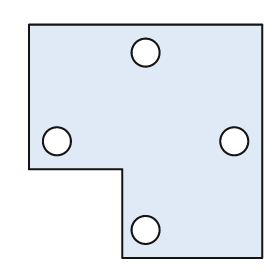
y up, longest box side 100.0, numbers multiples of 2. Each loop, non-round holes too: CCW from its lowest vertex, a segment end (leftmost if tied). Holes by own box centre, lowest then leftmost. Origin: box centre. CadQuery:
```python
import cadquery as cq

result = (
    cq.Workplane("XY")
    .moveTo(-10.0, -50.0)
    .lineTo(50.0, -50.0)
    .lineTo(50.0, 50.0)
    .lineTo(-50.0, 50.0)
    .lineTo(-50.0, -12.0)
    .lineTo(-10.0, -12.0)
    .close()
    .moveTo(0.0, -38.0)
    .circle(6.0)
    .moveTo(-38.0, 0.0)
    .circle(6.0)
    .moveTo(38.0, 0.0)
    .circle(6.0)
    .moveTo(0.0, 38.0)
    .circle(6.0)
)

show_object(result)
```